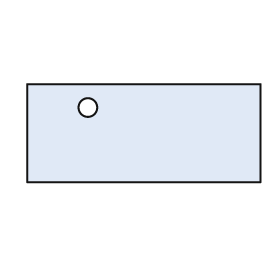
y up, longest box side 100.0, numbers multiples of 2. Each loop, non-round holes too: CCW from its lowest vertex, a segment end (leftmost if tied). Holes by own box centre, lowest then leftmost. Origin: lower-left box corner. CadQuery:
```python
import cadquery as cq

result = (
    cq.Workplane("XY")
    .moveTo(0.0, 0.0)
    .lineTo(100.0, 0.0)
    .lineTo(100.0, 42.0)
    .lineTo(0.0, 42.0)
    .close()
    .moveTo(26.0, 32.0)
    .circle(4.0)
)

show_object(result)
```